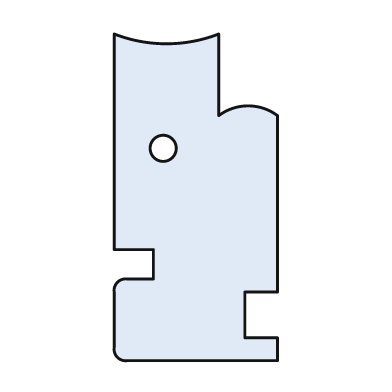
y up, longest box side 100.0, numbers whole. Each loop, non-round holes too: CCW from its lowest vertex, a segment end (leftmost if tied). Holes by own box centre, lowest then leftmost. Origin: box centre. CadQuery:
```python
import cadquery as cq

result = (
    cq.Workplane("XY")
    .moveTo(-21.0, -50.0)
    .lineTo(25.0, -50.0)
    .lineTo(25.0, -43.0)
    .lineTo(15.0, -43.0)
    .lineTo(15.0, -29.0)
    .lineTo(25.0, -29.0)
    .lineTo(25.0, 25.0)
    .threePointArc((16.0, 28.0), (7.0, 25.0))
    .lineTo(7.0, 50.0)
    .threePointArc((-9.0, 47.0), (-25.0, 50.0))
    .lineTo(-25.0, -16.0)
    .lineTo(-13.0, -16.0)
    .lineTo(-13.0, -25.0)
    .lineTo(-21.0, -25.0)
    .threePointArc((-24.0, -26.0), (-25.0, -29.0))
    .lineTo(-25.0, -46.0)
    .threePointArc((-24.0, -49.0), (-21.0, -50.0))
    .close()
    .moveTo(-10.0, 15.0)
    .circle(4.0)
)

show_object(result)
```